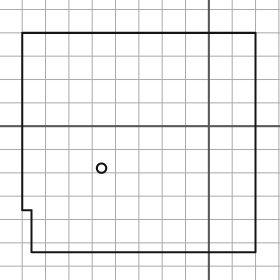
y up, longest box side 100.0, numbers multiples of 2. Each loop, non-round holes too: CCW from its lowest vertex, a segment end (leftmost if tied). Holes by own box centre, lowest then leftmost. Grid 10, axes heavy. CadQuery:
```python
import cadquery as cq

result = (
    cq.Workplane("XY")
    .moveTo(-76.0, -54.0)
    .lineTo(20.0, -54.0)
    .lineTo(20.0, 40.0)
    .lineTo(-80.0, 40.0)
    .lineTo(-80.0, -36.0)
    .lineTo(-76.0, -36.0)
    .close()
    .moveTo(-46.0, -18.0)
    .circle(2.0)
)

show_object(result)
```